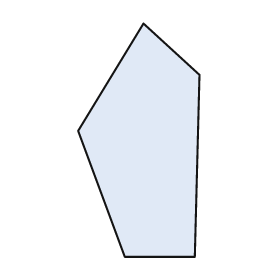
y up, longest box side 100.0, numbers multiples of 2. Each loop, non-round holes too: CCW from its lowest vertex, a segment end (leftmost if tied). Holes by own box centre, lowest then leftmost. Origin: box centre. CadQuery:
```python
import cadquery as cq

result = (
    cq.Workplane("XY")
    .moveTo(-6.0, -50.0)
    .lineTo(24.0, -50.0)
    .lineTo(26.0, 28.0)
    .lineTo(2.0, 50.0)
    .lineTo(-26.0, 4.0)
    .close()
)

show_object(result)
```